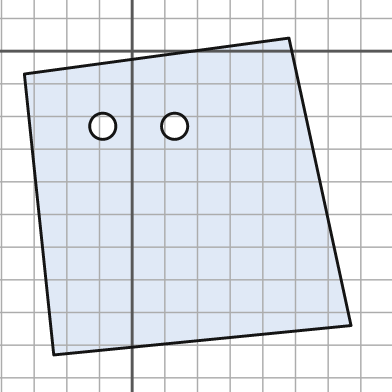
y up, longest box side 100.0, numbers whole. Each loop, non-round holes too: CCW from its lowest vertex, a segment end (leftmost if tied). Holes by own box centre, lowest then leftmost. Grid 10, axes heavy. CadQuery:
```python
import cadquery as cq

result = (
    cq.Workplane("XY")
    .moveTo(-24.0, -93.0)
    .lineTo(67.0, -84.0)
    .lineTo(48.0, 4.0)
    .lineTo(-33.0, -7.0)
    .close()
    .moveTo(-9.0, -23.0)
    .circle(4.0)
    .moveTo(13.0, -23.0)
    .circle(4.0)
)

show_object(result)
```